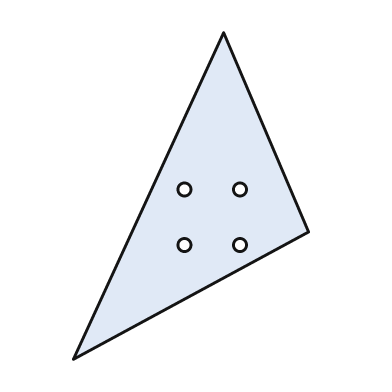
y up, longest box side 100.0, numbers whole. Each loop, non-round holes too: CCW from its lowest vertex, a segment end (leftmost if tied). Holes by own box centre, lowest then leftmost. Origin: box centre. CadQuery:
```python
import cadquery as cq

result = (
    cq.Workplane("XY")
    .moveTo(-36.0, -50.0)
    .lineTo(36.0, -11.0)
    .lineTo(10.0, 50.0)
    .close()
    .moveTo(-2.0, -15.0)
    .circle(2.0)
    .moveTo(15.0, -15.0)
    .circle(2.0)
    .moveTo(-2.0, 2.0)
    .circle(2.0)
    .moveTo(15.0, 2.0)
    .circle(2.0)
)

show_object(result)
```